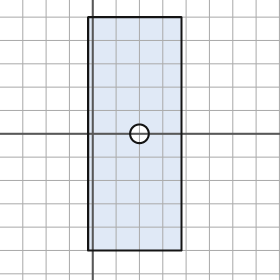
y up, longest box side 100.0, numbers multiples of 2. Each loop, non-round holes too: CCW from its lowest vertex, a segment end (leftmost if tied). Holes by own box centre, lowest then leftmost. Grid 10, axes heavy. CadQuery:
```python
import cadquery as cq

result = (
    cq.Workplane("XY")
    .moveTo(-2.0, -50.0)
    .lineTo(38.0, -50.0)
    .lineTo(38.0, 50.0)
    .lineTo(-2.0, 50.0)
    .close()
    .moveTo(20.0, 0.0)
    .circle(4.0)
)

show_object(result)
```